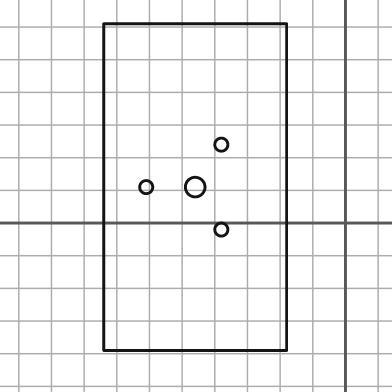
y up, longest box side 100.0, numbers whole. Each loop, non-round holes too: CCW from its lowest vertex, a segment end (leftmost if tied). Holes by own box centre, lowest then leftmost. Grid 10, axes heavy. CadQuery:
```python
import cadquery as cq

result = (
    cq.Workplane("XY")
    .moveTo(-74.0, -39.0)
    .lineTo(-18.0, -39.0)
    .lineTo(-18.0, 61.0)
    .lineTo(-74.0, 61.0)
    .close()
    .moveTo(-38.0, -2.0)
    .circle(2.0)
    .moveTo(-61.0, 11.0)
    .circle(2.0)
    .moveTo(-46.0, 11.0)
    .circle(3.0)
    .moveTo(-38.0, 24.0)
    .circle(2.0)
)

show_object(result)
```